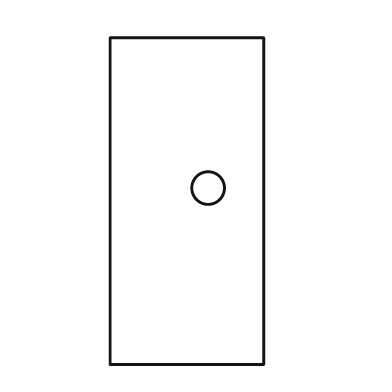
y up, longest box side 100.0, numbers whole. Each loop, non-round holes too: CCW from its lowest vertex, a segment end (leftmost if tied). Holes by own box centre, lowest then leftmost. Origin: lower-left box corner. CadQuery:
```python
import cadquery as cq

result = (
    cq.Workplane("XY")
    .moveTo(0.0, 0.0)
    .lineTo(47.0, 0.0)
    .lineTo(47.0, 100.0)
    .lineTo(0.0, 100.0)
    .close()
    .moveTo(30.0, 54.0)
    .circle(5.0)
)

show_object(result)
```